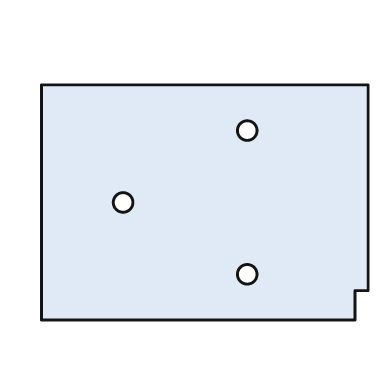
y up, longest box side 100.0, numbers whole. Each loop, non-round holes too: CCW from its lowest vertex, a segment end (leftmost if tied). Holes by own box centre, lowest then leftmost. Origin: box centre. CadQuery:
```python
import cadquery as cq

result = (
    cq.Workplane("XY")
    .moveTo(-50.0, -36.0)
    .lineTo(46.0, -36.0)
    .lineTo(46.0, -27.0)
    .lineTo(50.0, -27.0)
    .lineTo(50.0, 36.0)
    .lineTo(-50.0, 36.0)
    .close()
    .moveTo(13.0, -22.0)
    .circle(3.0)
    .moveTo(-25.0, 0.0)
    .circle(3.0)
    .moveTo(13.0, 22.0)
    .circle(3.0)
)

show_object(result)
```